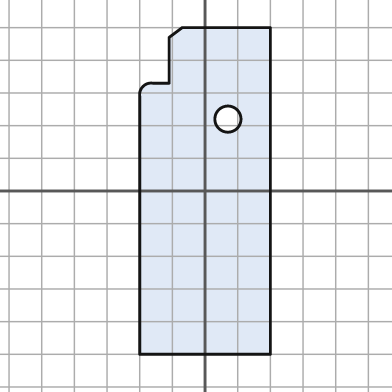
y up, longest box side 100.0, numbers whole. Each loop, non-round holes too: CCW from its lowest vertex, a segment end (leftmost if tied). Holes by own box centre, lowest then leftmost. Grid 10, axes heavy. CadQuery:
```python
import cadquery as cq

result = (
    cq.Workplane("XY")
    .moveTo(-20.0, -50.0)
    .lineTo(20.0, -50.0)
    .lineTo(20.0, 50.0)
    .lineTo(-7.0, 50.0)
    .lineTo(-11.0, 47.0)
    .lineTo(-11.0, 33.0)
    .lineTo(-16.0, 33.0)
    .threePointArc((-19.0, 32.0), (-20.0, 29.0))
    .close()
    .moveTo(7.0, 22.0)
    .circle(4.0)
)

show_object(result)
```